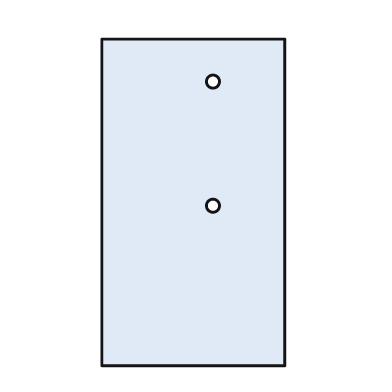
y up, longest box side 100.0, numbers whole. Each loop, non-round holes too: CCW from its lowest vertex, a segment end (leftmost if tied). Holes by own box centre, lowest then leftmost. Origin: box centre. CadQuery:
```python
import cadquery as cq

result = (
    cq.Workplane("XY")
    .moveTo(-28.0, -50.0)
    .lineTo(28.0, -50.0)
    .lineTo(28.0, 50.0)
    .lineTo(-28.0, 50.0)
    .close()
    .moveTo(6.0, -1.0)
    .circle(2.0)
    .moveTo(6.0, 37.0)
    .circle(2.0)
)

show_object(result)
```